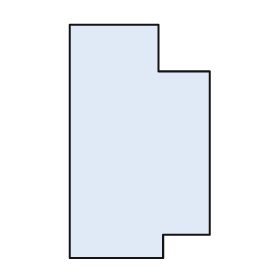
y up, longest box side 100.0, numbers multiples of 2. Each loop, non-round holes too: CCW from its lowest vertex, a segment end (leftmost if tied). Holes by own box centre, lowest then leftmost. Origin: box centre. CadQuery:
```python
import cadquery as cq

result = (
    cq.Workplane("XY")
    .moveTo(-30.0, -50.0)
    .lineTo(10.0, -50.0)
    .lineTo(10.0, -40.0)
    .lineTo(30.0, -40.0)
    .lineTo(30.0, 30.0)
    .lineTo(8.0, 30.0)
    .lineTo(8.0, 50.0)
    .lineTo(-30.0, 50.0)
    .close()
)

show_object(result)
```